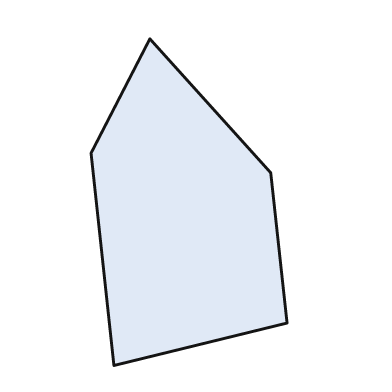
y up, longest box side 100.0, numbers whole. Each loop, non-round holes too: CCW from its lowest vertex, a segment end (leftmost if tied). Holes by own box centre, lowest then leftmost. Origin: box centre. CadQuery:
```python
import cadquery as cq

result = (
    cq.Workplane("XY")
    .moveTo(-23.0, -50.0)
    .lineTo(30.0, -37.0)
    .lineTo(25.0, 9.0)
    .lineTo(-12.0, 50.0)
    .lineTo(-30.0, 15.0)
    .close()
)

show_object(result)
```